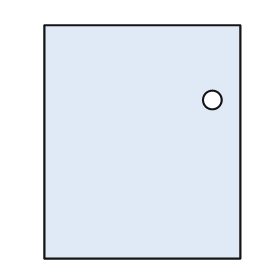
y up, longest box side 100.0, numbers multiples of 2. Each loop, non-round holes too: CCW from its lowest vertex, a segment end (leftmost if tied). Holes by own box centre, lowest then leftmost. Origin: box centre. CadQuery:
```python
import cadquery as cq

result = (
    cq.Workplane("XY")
    .moveTo(-42.0, -50.0)
    .lineTo(42.0, -50.0)
    .lineTo(42.0, 50.0)
    .lineTo(-42.0, 50.0)
    .close()
    .moveTo(30.0, 18.0)
    .circle(4.0)
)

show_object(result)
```